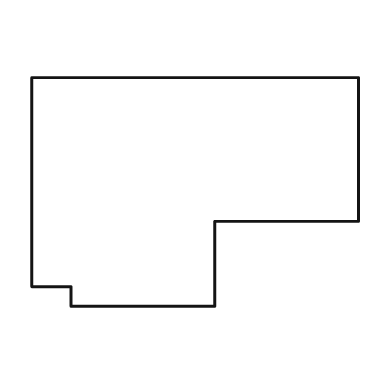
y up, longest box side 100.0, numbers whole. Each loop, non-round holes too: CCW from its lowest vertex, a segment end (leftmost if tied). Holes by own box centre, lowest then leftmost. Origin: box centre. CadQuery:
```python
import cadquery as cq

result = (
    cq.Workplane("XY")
    .moveTo(-38.0, -35.0)
    .lineTo(6.0, -35.0)
    .lineTo(6.0, -9.0)
    .lineTo(50.0, -9.0)
    .lineTo(50.0, 35.0)
    .lineTo(-50.0, 35.0)
    .lineTo(-50.0, -29.0)
    .lineTo(-38.0, -29.0)
    .close()
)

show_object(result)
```